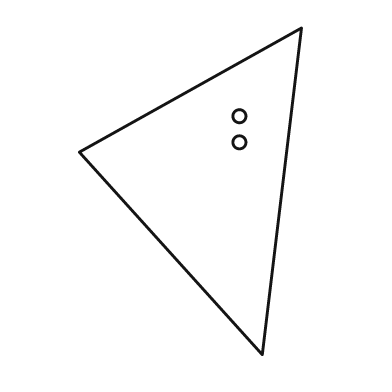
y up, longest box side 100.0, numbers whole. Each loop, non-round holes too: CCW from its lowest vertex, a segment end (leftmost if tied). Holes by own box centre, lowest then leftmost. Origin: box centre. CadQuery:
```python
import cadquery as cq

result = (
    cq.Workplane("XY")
    .moveTo(22.0, -50.0)
    .lineTo(34.0, 50.0)
    .lineTo(-34.0, 12.0)
    .close()
    .moveTo(15.0, 15.0)
    .circle(2.0)
    .moveTo(15.0, 23.0)
    .circle(2.0)
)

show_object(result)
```